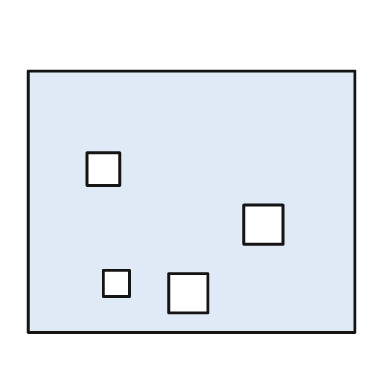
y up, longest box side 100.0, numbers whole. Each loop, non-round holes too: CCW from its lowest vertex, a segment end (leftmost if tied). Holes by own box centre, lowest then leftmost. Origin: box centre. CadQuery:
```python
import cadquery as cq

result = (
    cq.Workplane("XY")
    .moveTo(-50.0, -40.0)
    .lineTo(50.0, -40.0)
    .lineTo(50.0, 40.0)
    .lineTo(-50.0, 40.0)
    .close()
    .moveTo(-7.0, -34.0)
    .lineTo(5.0, -34.0)
    .lineTo(5.0, -22.0)
    .lineTo(-7.0, -22.0)
    .close()
    .moveTo(-27.0, -29.0)
    .lineTo(-19.0, -29.0)
    .lineTo(-19.0, -21.0)
    .lineTo(-27.0, -21.0)
    .close()
    .moveTo(16.0, -13.0)
    .lineTo(28.0, -13.0)
    .lineTo(28.0, -1.0)
    .lineTo(16.0, -1.0)
    .close()
    .moveTo(-32.0, 5.0)
    .lineTo(-22.0, 5.0)
    .lineTo(-22.0, 15.0)
    .lineTo(-32.0, 15.0)
    .close()
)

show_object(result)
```